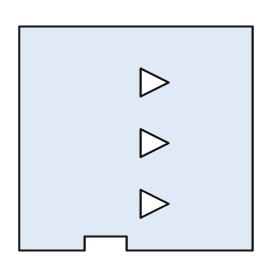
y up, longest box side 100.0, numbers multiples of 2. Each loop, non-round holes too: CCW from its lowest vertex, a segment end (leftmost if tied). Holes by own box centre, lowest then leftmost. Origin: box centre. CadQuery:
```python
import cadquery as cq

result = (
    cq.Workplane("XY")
    .moveTo(-50.0, -48.0)
    .lineTo(-22.0, -48.0)
    .lineTo(-22.0, -42.0)
    .lineTo(-4.0, -42.0)
    .lineTo(-4.0, -48.0)
    .lineTo(50.0, -48.0)
    .lineTo(50.0, 48.0)
    .lineTo(-50.0, 48.0)
    .close()
    .moveTo(2.0, -34.0)
    .lineTo(14.0, -28.0)
    .lineTo(2.0, -22.0)
    .close()
    .moveTo(2.0, -8.0)
    .lineTo(14.0, -2.0)
    .lineTo(2.0, 4.0)
    .close()
    .moveTo(2.0, 18.0)
    .lineTo(14.0, 24.0)
    .lineTo(2.0, 30.0)
    .close()
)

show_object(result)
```